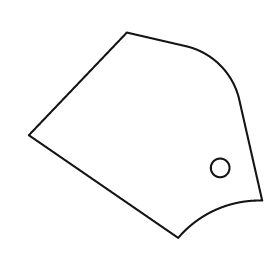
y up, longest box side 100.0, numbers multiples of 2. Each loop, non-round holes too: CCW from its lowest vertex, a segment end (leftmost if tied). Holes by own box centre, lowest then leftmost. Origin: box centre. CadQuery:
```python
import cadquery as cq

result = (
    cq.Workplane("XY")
    .moveTo(14.0, -44.0)
    .threePointArc((30.0, -32.0), (50.0, -28.0))
    .lineTo(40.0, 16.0)
    .threePointArc((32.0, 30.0), (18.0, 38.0))
    .lineTo(-8.0, 44.0)
    .lineTo(-50.0, 0.0)
    .close()
    .moveTo(32.0, -14.0)
    .circle(4.0)
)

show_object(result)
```